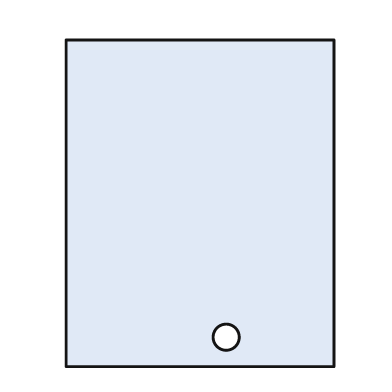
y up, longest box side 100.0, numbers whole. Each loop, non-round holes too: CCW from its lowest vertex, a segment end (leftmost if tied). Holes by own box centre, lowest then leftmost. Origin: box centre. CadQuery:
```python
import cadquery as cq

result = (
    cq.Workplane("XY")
    .moveTo(-41.0, -50.0)
    .lineTo(41.0, -50.0)
    .lineTo(41.0, 50.0)
    .lineTo(-41.0, 50.0)
    .close()
    .moveTo(8.0, -41.0)
    .circle(4.0)
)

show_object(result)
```